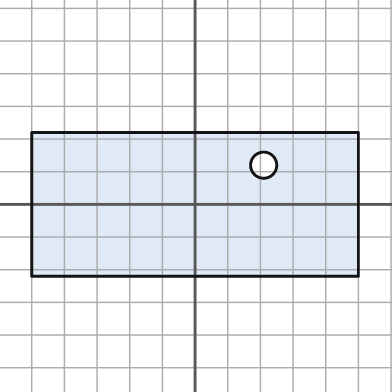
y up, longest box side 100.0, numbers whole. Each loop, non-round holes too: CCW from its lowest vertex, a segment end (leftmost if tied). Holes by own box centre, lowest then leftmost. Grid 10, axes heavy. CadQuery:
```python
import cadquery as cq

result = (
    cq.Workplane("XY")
    .moveTo(-50.0, -22.0)
    .lineTo(50.0, -22.0)
    .lineTo(50.0, 22.0)
    .lineTo(-50.0, 22.0)
    .close()
    .moveTo(21.0, 12.0)
    .circle(4.0)
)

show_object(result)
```